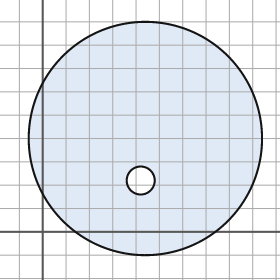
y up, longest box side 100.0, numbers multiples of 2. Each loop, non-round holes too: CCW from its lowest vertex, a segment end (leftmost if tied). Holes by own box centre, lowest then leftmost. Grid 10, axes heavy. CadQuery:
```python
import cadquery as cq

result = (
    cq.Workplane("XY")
    .moveTo(44.0, 40.0)
    .circle(50.0)
    .moveTo(42.0, 22.0)
    .circle(6.0)
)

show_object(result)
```